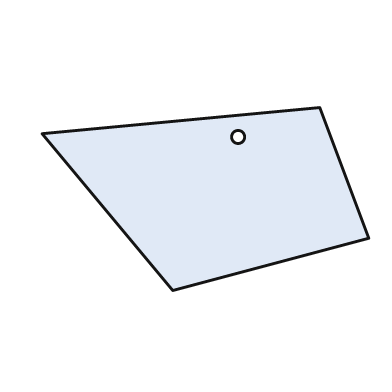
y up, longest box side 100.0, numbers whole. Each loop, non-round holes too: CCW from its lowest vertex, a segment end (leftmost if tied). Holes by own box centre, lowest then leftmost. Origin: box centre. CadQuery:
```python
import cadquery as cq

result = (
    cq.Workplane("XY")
    .moveTo(-10.0, -28.0)
    .lineTo(50.0, -12.0)
    .lineTo(35.0, 28.0)
    .lineTo(-50.0, 20.0)
    .close()
    .moveTo(10.0, 19.0)
    .circle(2.0)
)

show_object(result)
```